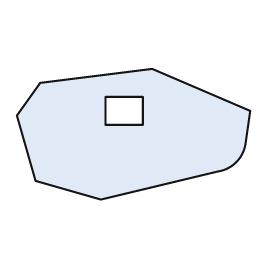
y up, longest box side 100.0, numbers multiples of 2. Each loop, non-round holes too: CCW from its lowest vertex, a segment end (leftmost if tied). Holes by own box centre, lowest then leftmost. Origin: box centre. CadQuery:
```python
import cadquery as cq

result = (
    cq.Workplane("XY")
    .moveTo(-14.0, -28.0)
    .lineTo(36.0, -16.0)
    .threePointArc((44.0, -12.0), (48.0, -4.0))
    .lineTo(50.0, 10.0)
    .lineTo(8.0, 28.0)
    .lineTo(-40.0, 22.0)
    .lineTo(-50.0, 8.0)
    .lineTo(-42.0, -20.0)
    .close()
    .moveTo(-12.0, 4.0)
    .lineTo(4.0, 4.0)
    .lineTo(4.0, 16.0)
    .lineTo(-12.0, 16.0)
    .close()
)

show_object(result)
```